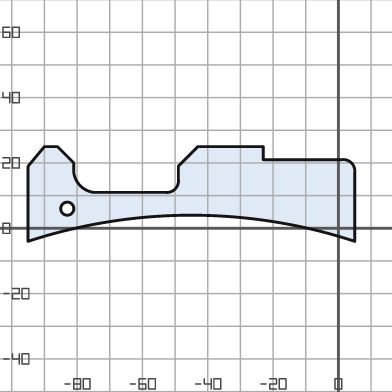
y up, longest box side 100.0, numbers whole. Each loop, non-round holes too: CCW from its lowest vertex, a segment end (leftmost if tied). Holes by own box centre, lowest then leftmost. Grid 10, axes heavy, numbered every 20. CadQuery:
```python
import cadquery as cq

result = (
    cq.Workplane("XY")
    .moveTo(-95.0, -4.0)
    .threePointArc((-45.0, 4.0), (5.0, -4.0))
    .lineTo(5.0, 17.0)
    .threePointArc((4.0, 20.0), (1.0, 21.0))
    .lineTo(-23.0, 21.0)
    .lineTo(-23.0, 25.0)
    .lineTo(-43.0, 25.0)
    .lineTo(-49.0, 19.0)
    .lineTo(-49.0, 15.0)
    .threePointArc((-50.0, 12.0), (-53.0, 11.0))
    .lineTo(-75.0, 11.0)
    .threePointArc((-79.0, 13.0), (-81.0, 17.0))
    .lineTo(-81.0, 20.0)
    .lineTo(-86.0, 25.0)
    .lineTo(-90.0, 25.0)
    .lineTo(-95.0, 19.0)
    .close()
    .moveTo(-83.0, 6.0)
    .circle(2.0)
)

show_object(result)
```